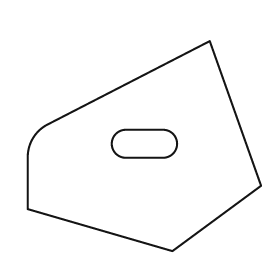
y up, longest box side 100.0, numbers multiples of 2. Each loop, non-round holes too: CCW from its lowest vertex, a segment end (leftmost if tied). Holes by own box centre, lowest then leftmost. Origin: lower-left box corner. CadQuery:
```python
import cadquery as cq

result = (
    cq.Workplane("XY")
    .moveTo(62.0, 0.0)
    .lineTo(100.0, 28.0)
    .lineTo(78.0, 90.0)
    .lineTo(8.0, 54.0)
    .threePointArc((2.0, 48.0), (0.0, 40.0))
    .lineTo(0.0, 18.0)
    .close()
    .moveTo(42.0, 40.0)
    .lineTo(58.0, 40.0)
    .threePointArc((64.0, 46.0), (58.0, 52.0))
    .lineTo(42.0, 52.0)
    .threePointArc((36.0, 46.0), (42.0, 40.0))
    .close()
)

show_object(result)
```